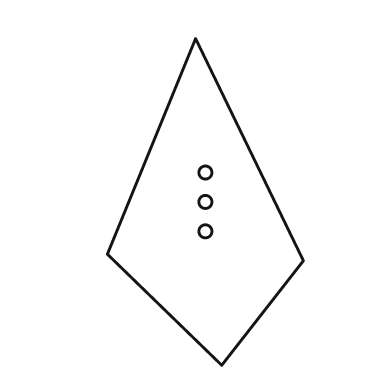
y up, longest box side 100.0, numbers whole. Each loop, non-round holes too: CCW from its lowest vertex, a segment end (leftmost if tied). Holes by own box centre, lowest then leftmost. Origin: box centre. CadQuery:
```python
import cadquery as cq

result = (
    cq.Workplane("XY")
    .moveTo(5.0, -50.0)
    .lineTo(30.0, -18.0)
    .lineTo(-3.0, 50.0)
    .lineTo(-30.0, -16.0)
    .close()
    .moveTo(0.0, -9.0)
    .circle(2.0)
    .moveTo(0.0, 0.0)
    .circle(2.0)
    .moveTo(0.0, 9.0)
    .circle(2.0)
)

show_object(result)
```